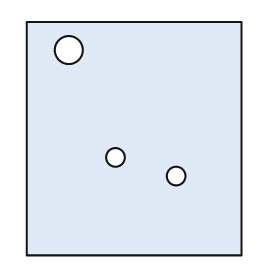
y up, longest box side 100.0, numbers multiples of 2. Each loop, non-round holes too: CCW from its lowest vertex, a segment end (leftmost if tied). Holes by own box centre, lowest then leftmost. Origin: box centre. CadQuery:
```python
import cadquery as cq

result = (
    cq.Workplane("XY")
    .moveTo(-46.0, -50.0)
    .lineTo(46.0, -50.0)
    .lineTo(46.0, 50.0)
    .lineTo(-46.0, 50.0)
    .close()
    .moveTo(18.0, -16.0)
    .circle(4.0)
    .moveTo(-8.0, -8.0)
    .circle(4.0)
    .moveTo(-28.0, 38.0)
    .circle(6.0)
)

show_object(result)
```